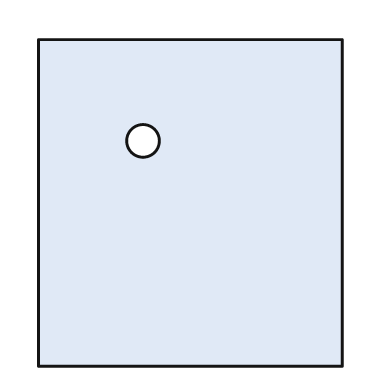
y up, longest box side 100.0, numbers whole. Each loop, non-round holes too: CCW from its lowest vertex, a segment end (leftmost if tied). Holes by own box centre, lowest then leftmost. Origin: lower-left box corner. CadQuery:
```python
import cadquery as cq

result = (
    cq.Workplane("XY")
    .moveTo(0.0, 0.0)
    .lineTo(93.0, 0.0)
    .lineTo(93.0, 100.0)
    .lineTo(0.0, 100.0)
    .close()
    .moveTo(32.0, 69.0)
    .circle(5.0)
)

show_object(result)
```